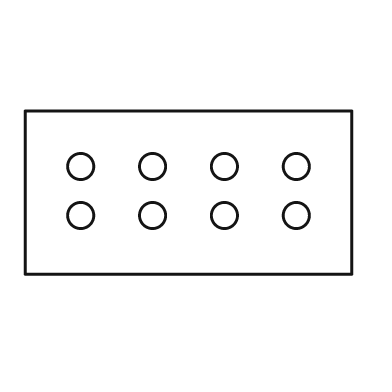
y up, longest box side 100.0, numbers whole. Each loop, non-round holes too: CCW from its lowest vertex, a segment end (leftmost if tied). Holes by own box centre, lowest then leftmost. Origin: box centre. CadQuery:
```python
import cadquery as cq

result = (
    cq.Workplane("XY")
    .moveTo(-50.0, -25.0)
    .lineTo(50.0, -25.0)
    .lineTo(50.0, 25.0)
    .lineTo(-50.0, 25.0)
    .close()
    .moveTo(-33.0, -7.0)
    .circle(4.0)
    .moveTo(-11.0, -7.0)
    .circle(4.0)
    .moveTo(11.0, -7.0)
    .circle(4.0)
    .moveTo(33.0, -7.0)
    .circle(4.0)
    .moveTo(-33.0, 8.0)
    .circle(4.0)
    .moveTo(-11.0, 8.0)
    .circle(4.0)
    .moveTo(11.0, 8.0)
    .circle(4.0)
    .moveTo(33.0, 8.0)
    .circle(4.0)
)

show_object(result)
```